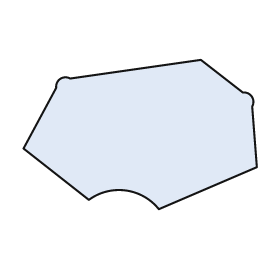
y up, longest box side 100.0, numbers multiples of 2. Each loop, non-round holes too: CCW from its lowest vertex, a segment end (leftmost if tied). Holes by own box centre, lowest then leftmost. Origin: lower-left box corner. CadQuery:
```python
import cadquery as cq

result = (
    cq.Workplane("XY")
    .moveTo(58.0, 0.0)
    .lineTo(100.0, 18.0)
    .lineTo(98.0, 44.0)
    .threePointArc((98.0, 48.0), (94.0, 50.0))
    .lineTo(76.0, 64.0)
    .lineTo(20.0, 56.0)
    .threePointArc((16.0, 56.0), (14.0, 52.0))
    .lineTo(0.0, 26.0)
    .lineTo(28.0, 4.0)
    .threePointArc((44.0, 8.0), (58.0, 0.0))
    .close()
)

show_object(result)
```